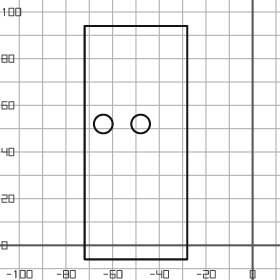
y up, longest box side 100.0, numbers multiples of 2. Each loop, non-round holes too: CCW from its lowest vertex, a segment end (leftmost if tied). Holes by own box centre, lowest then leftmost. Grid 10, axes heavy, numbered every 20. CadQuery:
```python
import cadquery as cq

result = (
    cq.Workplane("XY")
    .moveTo(-72.0, -6.0)
    .lineTo(-28.0, -6.0)
    .lineTo(-28.0, 94.0)
    .lineTo(-72.0, 94.0)
    .close()
    .moveTo(-64.0, 52.0)
    .circle(4.0)
    .moveTo(-48.0, 52.0)
    .circle(4.0)
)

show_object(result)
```